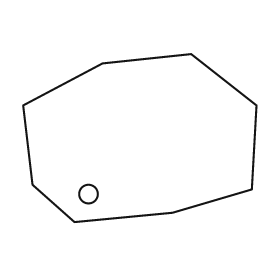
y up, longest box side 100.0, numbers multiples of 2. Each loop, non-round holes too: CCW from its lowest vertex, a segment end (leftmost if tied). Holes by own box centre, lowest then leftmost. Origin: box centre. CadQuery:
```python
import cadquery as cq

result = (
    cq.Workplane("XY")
    .moveTo(-28.0, -36.0)
    .lineTo(14.0, -32.0)
    .lineTo(48.0, -22.0)
    .lineTo(50.0, 14.0)
    .lineTo(22.0, 36.0)
    .lineTo(-16.0, 32.0)
    .lineTo(-50.0, 14.0)
    .lineTo(-46.0, -20.0)
    .close()
    .moveTo(-22.0, -24.0)
    .circle(4.0)
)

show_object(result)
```